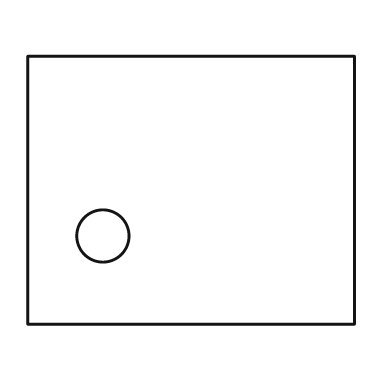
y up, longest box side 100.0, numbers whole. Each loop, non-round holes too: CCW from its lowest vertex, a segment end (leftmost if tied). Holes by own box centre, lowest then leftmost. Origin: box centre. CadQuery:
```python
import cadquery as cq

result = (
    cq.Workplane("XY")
    .moveTo(-50.0, -41.0)
    .lineTo(50.0, -41.0)
    .lineTo(50.0, 41.0)
    .lineTo(-50.0, 41.0)
    .close()
    .moveTo(-27.0, -14.0)
    .circle(8.0)
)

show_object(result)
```